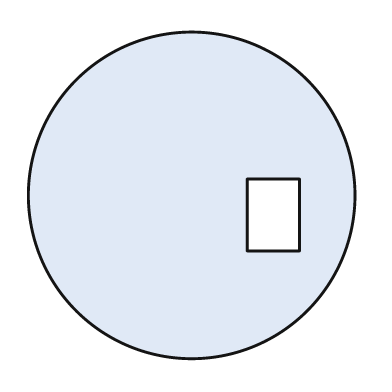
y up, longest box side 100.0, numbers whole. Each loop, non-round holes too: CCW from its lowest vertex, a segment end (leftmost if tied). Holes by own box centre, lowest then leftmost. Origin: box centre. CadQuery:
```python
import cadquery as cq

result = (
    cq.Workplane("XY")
    .moveTo(0.0, 0.0)
    .circle(50.0)
    .moveTo(17.0, -17.0)
    .lineTo(33.0, -17.0)
    .lineTo(33.0, 5.0)
    .lineTo(17.0, 5.0)
    .close()
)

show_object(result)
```